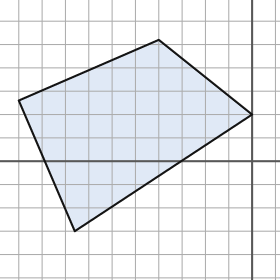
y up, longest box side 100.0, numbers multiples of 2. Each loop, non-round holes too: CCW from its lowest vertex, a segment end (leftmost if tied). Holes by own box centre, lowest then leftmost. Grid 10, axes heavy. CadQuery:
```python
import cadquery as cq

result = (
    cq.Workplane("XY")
    .moveTo(-76.0, -30.0)
    .lineTo(0.0, 20.0)
    .lineTo(-40.0, 52.0)
    .lineTo(-100.0, 26.0)
    .close()
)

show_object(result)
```